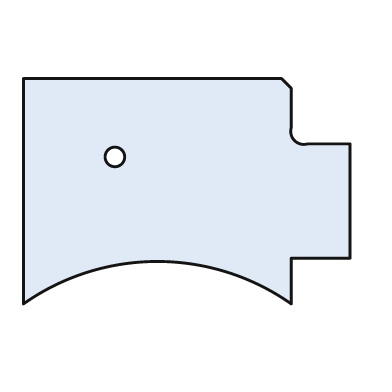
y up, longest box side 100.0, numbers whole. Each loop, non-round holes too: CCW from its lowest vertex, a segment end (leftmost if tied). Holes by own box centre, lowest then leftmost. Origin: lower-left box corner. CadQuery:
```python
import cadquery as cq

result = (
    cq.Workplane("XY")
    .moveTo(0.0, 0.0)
    .threePointArc((41.0, 13.0), (82.0, 0.0))
    .lineTo(82.0, 14.0)
    .lineTo(100.0, 14.0)
    .lineTo(100.0, 49.0)
    .lineTo(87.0, 49.0)
    .threePointArc((83.0, 50.0), (82.0, 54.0))
    .lineTo(82.0, 66.0)
    .lineTo(79.0, 69.0)
    .lineTo(0.0, 69.0)
    .close()
    .moveTo(28.0, 45.0)
    .circle(3.0)
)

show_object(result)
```